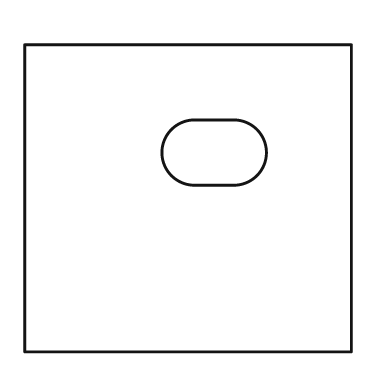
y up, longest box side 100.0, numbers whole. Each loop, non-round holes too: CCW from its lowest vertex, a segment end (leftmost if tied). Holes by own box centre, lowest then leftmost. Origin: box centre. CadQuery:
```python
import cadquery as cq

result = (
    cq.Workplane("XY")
    .moveTo(-50.0, -47.0)
    .lineTo(50.0, -47.0)
    .lineTo(50.0, 47.0)
    .lineTo(-50.0, 47.0)
    .close()
    .moveTo(2.0, 4.0)
    .lineTo(14.0, 4.0)
    .threePointArc((24.0, 14.0), (14.0, 24.0))
    .lineTo(2.0, 24.0)
    .threePointArc((-8.0, 14.0), (2.0, 4.0))
    .close()
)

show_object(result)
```